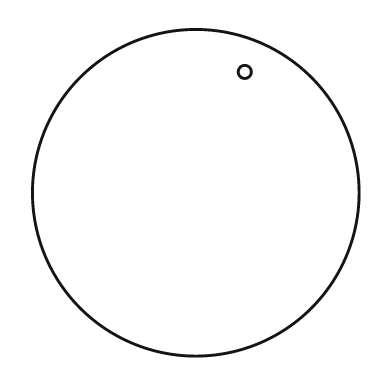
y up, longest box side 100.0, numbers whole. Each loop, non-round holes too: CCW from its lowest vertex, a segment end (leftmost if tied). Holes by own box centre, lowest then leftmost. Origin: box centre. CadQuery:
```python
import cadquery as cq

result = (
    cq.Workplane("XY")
    .moveTo(0.0, 0.0)
    .circle(50.0)
    .moveTo(15.0, 37.0)
    .circle(2.0)
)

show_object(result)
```